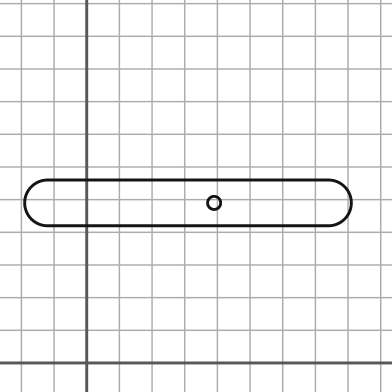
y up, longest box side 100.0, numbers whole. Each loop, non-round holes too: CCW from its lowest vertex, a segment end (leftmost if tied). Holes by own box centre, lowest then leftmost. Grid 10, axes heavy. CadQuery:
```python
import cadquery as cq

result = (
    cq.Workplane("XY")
    .moveTo(-12.0, 42.0)
    .lineTo(74.0, 42.0)
    .threePointArc((81.0, 49.0), (74.0, 56.0))
    .lineTo(-12.0, 56.0)
    .threePointArc((-19.0, 49.0), (-12.0, 42.0))
    .close()
    .moveTo(39.0, 49.0)
    .circle(2.0)
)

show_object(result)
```